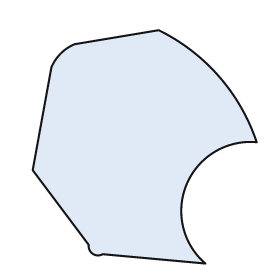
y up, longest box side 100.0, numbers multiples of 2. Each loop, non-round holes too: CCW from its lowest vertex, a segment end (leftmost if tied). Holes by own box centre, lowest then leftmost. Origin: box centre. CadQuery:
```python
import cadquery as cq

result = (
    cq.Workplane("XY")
    .moveTo(26.0, -50.0)
    .threePointArc((18.0, -16.0), (48.0, 2.0))
    .threePointArc((32.0, 30.0), (6.0, 50.0))
    .lineTo(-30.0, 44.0)
    .threePointArc((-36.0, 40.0), (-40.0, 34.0))
    .lineTo(-48.0, -10.0)
    .lineTo(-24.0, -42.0)
    .threePointArc((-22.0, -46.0), (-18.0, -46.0))
    .close()
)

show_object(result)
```